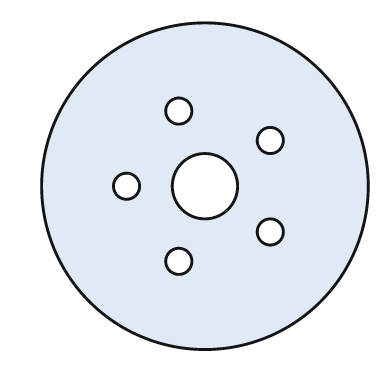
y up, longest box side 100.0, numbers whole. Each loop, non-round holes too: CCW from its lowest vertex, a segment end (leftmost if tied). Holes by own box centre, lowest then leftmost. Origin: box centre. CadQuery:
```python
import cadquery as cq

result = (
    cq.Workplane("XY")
    .moveTo(0.0, 0.0)
    .circle(50.0)
    .moveTo(-8.0, -23.0)
    .circle(4.0)
    .moveTo(20.0, -14.0)
    .circle(4.0)
    .moveTo(-24.0, 0.0)
    .circle(4.0)
    .moveTo(0.0, 0.0)
    .circle(10.0)
    .moveTo(20.0, 14.0)
    .circle(4.0)
    .moveTo(-8.0, 23.0)
    .circle(4.0)
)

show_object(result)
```